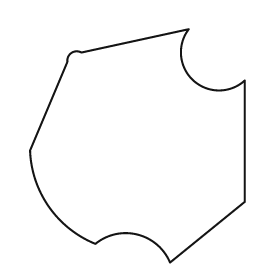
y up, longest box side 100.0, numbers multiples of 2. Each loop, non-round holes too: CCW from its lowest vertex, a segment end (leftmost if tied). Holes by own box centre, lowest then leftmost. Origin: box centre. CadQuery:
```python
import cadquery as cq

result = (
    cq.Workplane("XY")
    .moveTo(14.0, -50.0)
    .lineTo(46.0, -24.0)
    .lineTo(46.0, 28.0)
    .threePointArc((24.0, 28.0), (22.0, 50.0))
    .lineTo(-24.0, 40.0)
    .threePointArc((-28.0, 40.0), (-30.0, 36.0))
    .lineTo(-46.0, -2.0)
    .threePointArc((-38.0, -26.0), (-18.0, -42.0))
    .threePointArc((0.0, -38.0), (14.0, -50.0))
    .close()
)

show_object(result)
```